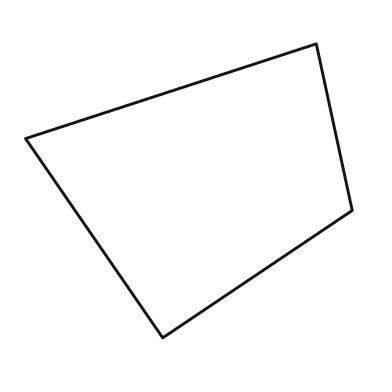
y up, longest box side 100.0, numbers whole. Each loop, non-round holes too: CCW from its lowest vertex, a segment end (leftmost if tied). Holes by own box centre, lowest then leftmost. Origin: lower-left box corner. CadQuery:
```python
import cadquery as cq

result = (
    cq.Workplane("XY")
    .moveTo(42.0, 0.0)
    .lineTo(100.0, 39.0)
    .lineTo(89.0, 90.0)
    .lineTo(0.0, 61.0)
    .close()
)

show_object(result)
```